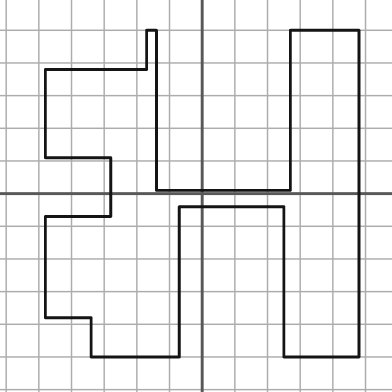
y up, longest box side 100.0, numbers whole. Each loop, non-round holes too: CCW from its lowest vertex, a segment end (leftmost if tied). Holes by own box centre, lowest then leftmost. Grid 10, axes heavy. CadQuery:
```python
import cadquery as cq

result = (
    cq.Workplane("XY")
    .moveTo(-34.0, -50.0)
    .lineTo(-7.0, -50.0)
    .lineTo(-7.0, -4.0)
    .lineTo(25.0, -4.0)
    .lineTo(25.0, -50.0)
    .lineTo(48.0, -50.0)
    .lineTo(48.0, 50.0)
    .lineTo(27.0, 50.0)
    .lineTo(27.0, 1.0)
    .lineTo(-14.0, 1.0)
    .lineTo(-14.0, 50.0)
    .lineTo(-17.0, 50.0)
    .lineTo(-17.0, 38.0)
    .lineTo(-48.0, 38.0)
    .lineTo(-48.0, 11.0)
    .lineTo(-28.0, 11.0)
    .lineTo(-28.0, -7.0)
    .lineTo(-48.0, -7.0)
    .lineTo(-48.0, -38.0)
    .lineTo(-34.0, -38.0)
    .close()
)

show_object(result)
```